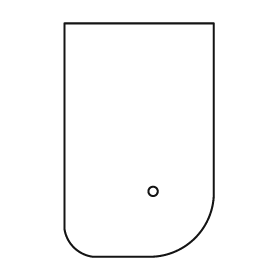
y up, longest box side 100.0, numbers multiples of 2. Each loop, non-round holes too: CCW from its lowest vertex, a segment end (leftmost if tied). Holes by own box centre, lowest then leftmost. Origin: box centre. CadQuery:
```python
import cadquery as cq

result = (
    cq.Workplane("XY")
    .moveTo(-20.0, -50.0)
    .lineTo(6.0, -50.0)
    .threePointArc((24.0, -42.0), (32.0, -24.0))
    .lineTo(32.0, 50.0)
    .lineTo(-32.0, 50.0)
    .lineTo(-32.0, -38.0)
    .threePointArc((-28.0, -46.0), (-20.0, -50.0))
    .close()
    .moveTo(6.0, -22.0)
    .circle(2.0)
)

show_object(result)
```